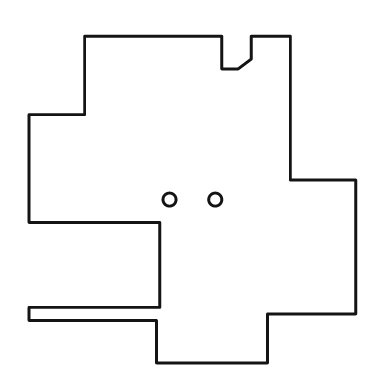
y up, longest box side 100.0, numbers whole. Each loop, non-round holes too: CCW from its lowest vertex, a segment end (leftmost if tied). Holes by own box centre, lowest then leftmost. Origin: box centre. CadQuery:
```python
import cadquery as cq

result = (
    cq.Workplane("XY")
    .moveTo(-11.0, -50.0)
    .lineTo(23.0, -50.0)
    .lineTo(23.0, -35.0)
    .lineTo(50.0, -35.0)
    .lineTo(50.0, 6.0)
    .lineTo(30.0, 6.0)
    .lineTo(30.0, 50.0)
    .lineTo(18.0, 50.0)
    .lineTo(18.0, 43.0)
    .lineTo(14.0, 40.0)
    .lineTo(9.0, 40.0)
    .lineTo(9.0, 50.0)
    .lineTo(-33.0, 50.0)
    .lineTo(-33.0, 26.0)
    .lineTo(-50.0, 26.0)
    .lineTo(-50.0, -7.0)
    .lineTo(-10.0, -7.0)
    .lineTo(-10.0, -33.0)
    .lineTo(-50.0, -33.0)
    .lineTo(-50.0, -37.0)
    .lineTo(-11.0, -37.0)
    .close()
    .moveTo(-7.0, 0.0)
    .circle(2.0)
    .moveTo(7.0, 0.0)
    .circle(2.0)
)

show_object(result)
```